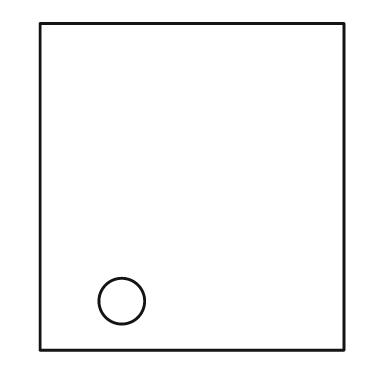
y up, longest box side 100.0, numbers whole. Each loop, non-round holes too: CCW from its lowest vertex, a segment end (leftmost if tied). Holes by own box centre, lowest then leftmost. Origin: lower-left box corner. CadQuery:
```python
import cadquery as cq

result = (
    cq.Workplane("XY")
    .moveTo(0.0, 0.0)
    .lineTo(93.0, 0.0)
    .lineTo(93.0, 100.0)
    .lineTo(0.0, 100.0)
    .close()
    .moveTo(25.0, 15.0)
    .circle(7.0)
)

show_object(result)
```